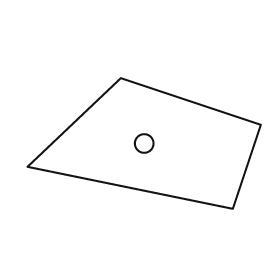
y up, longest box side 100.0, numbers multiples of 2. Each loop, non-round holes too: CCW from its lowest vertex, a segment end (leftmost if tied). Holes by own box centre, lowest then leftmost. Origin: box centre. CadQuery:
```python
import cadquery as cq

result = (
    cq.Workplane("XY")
    .moveTo(38.0, -28.0)
    .lineTo(50.0, 8.0)
    .lineTo(-10.0, 28.0)
    .lineTo(-50.0, -10.0)
    .close()
    .moveTo(0.0, 0.0)
    .circle(4.0)
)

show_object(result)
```